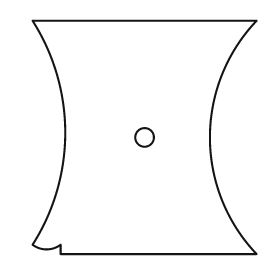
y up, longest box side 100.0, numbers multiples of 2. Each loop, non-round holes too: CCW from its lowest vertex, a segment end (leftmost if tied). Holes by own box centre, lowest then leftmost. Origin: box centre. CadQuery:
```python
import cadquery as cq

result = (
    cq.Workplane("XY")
    .moveTo(-36.0, -50.0)
    .lineTo(48.0, -50.0)
    .threePointArc((28.0, 0.0), (48.0, 50.0))
    .lineTo(-48.0, 50.0)
    .threePointArc((-34.0, 2.0), (-48.0, -46.0))
    .threePointArc((-42.0, -48.0), (-36.0, -46.0))
    .close()
    .moveTo(0.0, 0.0)
    .circle(4.0)
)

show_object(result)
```